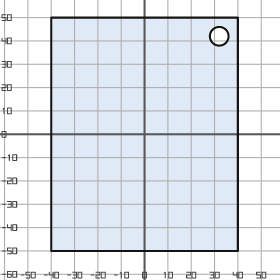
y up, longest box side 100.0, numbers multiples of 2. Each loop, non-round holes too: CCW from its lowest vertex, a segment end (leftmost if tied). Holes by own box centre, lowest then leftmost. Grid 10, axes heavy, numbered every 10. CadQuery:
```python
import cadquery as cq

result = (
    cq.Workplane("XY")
    .moveTo(-40.0, -50.0)
    .lineTo(40.0, -50.0)
    .lineTo(40.0, 50.0)
    .lineTo(-40.0, 50.0)
    .close()
    .moveTo(32.0, 42.0)
    .circle(4.0)
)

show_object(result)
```